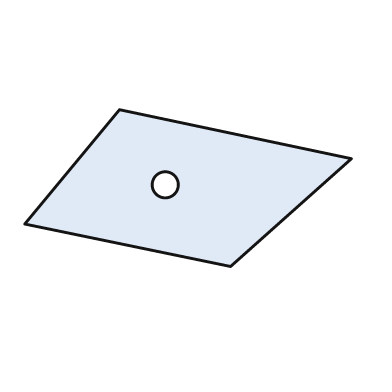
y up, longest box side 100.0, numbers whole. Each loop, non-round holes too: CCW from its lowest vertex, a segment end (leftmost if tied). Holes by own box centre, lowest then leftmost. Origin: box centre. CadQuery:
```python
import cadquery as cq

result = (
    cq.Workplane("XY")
    .moveTo(13.0, -24.0)
    .lineTo(50.0, 9.0)
    .lineTo(-21.0, 24.0)
    .lineTo(-50.0, -11.0)
    .close()
    .moveTo(-7.0, 1.0)
    .circle(4.0)
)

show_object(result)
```